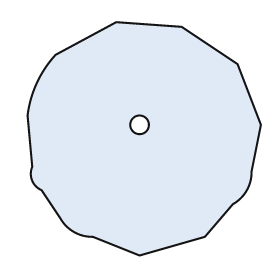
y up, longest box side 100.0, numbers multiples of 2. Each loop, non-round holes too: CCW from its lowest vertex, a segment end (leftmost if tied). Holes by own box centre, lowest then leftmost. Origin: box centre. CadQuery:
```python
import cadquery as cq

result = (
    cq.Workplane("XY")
    .moveTo(-2.0, -50.0)
    .lineTo(26.0, -42.0)
    .lineTo(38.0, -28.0)
    .threePointArc((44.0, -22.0), (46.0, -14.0))
    .lineTo(50.0, 6.0)
    .lineTo(40.0, 32.0)
    .lineTo(16.0, 48.0)
    .lineTo(-12.0, 50.0)
    .lineTo(-38.0, 36.0)
    .threePointArc((-46.0, 24.0), (-50.0, 10.0))
    .lineTo(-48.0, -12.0)
    .threePointArc((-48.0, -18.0), (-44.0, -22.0))
    .lineTo(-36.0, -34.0)
    .threePointArc((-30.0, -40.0), (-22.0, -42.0))
    .close()
    .moveTo(-2.0, 6.0)
    .circle(4.0)
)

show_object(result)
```